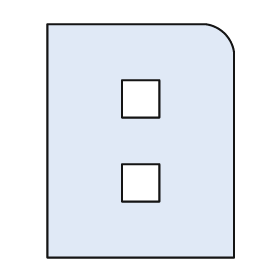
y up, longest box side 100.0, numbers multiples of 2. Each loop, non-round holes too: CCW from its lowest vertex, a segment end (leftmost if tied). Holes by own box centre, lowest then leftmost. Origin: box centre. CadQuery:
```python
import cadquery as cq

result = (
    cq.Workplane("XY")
    .moveTo(-40.0, -50.0)
    .lineTo(40.0, -50.0)
    .lineTo(40.0, 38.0)
    .threePointArc((36.0, 46.0), (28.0, 50.0))
    .lineTo(-40.0, 50.0)
    .close()
    .moveTo(-8.0, -26.0)
    .lineTo(8.0, -26.0)
    .lineTo(8.0, -10.0)
    .lineTo(-8.0, -10.0)
    .close()
    .moveTo(-8.0, 10.0)
    .lineTo(8.0, 10.0)
    .lineTo(8.0, 26.0)
    .lineTo(-8.0, 26.0)
    .close()
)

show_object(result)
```